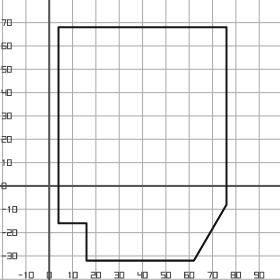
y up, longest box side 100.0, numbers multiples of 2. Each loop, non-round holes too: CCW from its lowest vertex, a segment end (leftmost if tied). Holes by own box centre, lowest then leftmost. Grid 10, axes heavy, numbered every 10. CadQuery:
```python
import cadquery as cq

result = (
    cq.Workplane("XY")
    .moveTo(16.0, -32.0)
    .lineTo(62.0, -32.0)
    .lineTo(76.0, -8.0)
    .lineTo(76.0, 68.0)
    .lineTo(4.0, 68.0)
    .lineTo(4.0, -16.0)
    .lineTo(16.0, -16.0)
    .close()
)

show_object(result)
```